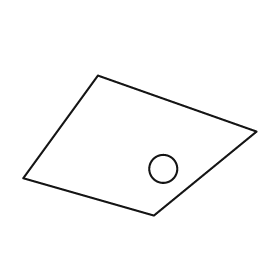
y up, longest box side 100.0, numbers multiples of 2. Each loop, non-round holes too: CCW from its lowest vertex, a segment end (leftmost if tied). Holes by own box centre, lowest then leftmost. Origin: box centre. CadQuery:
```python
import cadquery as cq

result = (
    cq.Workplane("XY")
    .moveTo(6.0, -30.0)
    .lineTo(50.0, 6.0)
    .lineTo(-18.0, 30.0)
    .lineTo(-50.0, -14.0)
    .close()
    .moveTo(10.0, -10.0)
    .circle(6.0)
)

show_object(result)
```